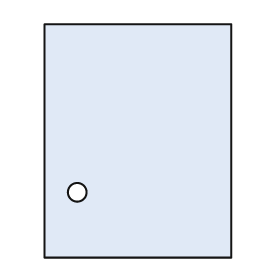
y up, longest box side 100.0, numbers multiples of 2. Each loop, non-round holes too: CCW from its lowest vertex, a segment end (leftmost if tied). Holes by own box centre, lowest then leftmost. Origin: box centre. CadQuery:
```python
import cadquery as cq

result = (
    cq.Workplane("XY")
    .moveTo(-40.0, -50.0)
    .lineTo(40.0, -50.0)
    .lineTo(40.0, 50.0)
    .lineTo(-40.0, 50.0)
    .close()
    .moveTo(-26.0, -22.0)
    .circle(4.0)
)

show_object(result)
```